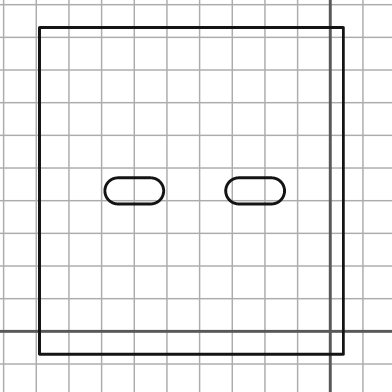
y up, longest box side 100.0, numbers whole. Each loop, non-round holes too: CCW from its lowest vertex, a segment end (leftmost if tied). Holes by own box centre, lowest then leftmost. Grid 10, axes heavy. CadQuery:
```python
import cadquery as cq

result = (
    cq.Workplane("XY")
    .moveTo(-89.0, -7.0)
    .lineTo(4.0, -7.0)
    .lineTo(4.0, 93.0)
    .lineTo(-89.0, 93.0)
    .close()
    .moveTo(-65.0, 39.0)
    .lineTo(-55.0, 39.0)
    .threePointArc((-51.0, 43.0), (-55.0, 47.0))
    .lineTo(-65.0, 47.0)
    .threePointArc((-69.0, 43.0), (-65.0, 39.0))
    .close()
    .moveTo(-28.0, 39.0)
    .lineTo(-18.0, 39.0)
    .threePointArc((-14.0, 43.0), (-18.0, 47.0))
    .lineTo(-28.0, 47.0)
    .threePointArc((-32.0, 43.0), (-28.0, 39.0))
    .close()
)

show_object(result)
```